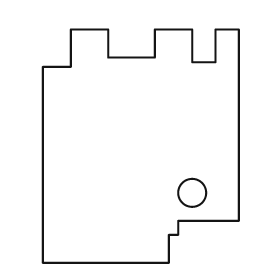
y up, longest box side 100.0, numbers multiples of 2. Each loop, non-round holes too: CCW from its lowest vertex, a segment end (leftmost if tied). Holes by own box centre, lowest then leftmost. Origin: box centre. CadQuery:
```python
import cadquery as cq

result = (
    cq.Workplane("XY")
    .moveTo(-42.0, -50.0)
    .lineTo(12.0, -50.0)
    .lineTo(12.0, -38.0)
    .lineTo(16.0, -38.0)
    .lineTo(16.0, -32.0)
    .lineTo(42.0, -32.0)
    .lineTo(42.0, 50.0)
    .lineTo(32.0, 50.0)
    .lineTo(32.0, 36.0)
    .lineTo(22.0, 36.0)
    .lineTo(22.0, 50.0)
    .lineTo(6.0, 50.0)
    .lineTo(6.0, 38.0)
    .lineTo(-14.0, 38.0)
    .lineTo(-14.0, 50.0)
    .lineTo(-30.0, 50.0)
    .lineTo(-30.0, 34.0)
    .lineTo(-42.0, 34.0)
    .close()
    .moveTo(22.0, -20.0)
    .circle(6.0)
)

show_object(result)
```